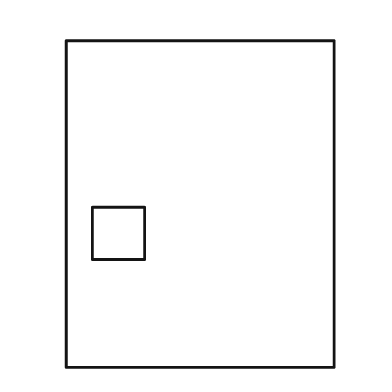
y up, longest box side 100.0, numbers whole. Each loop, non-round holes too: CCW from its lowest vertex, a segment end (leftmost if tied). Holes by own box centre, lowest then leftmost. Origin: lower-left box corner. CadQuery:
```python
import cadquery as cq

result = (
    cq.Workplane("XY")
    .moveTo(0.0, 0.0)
    .lineTo(82.0, 0.0)
    .lineTo(82.0, 100.0)
    .lineTo(0.0, 100.0)
    .close()
    .moveTo(8.0, 33.0)
    .lineTo(24.0, 33.0)
    .lineTo(24.0, 49.0)
    .lineTo(8.0, 49.0)
    .close()
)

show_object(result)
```